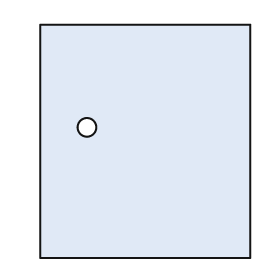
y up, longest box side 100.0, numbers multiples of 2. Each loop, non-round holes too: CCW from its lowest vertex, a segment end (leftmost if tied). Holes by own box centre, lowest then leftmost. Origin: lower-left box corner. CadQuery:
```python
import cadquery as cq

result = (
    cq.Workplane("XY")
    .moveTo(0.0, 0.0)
    .lineTo(90.0, 0.0)
    .lineTo(90.0, 100.0)
    .lineTo(0.0, 100.0)
    .close()
    .moveTo(20.0, 56.0)
    .circle(4.0)
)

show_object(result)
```